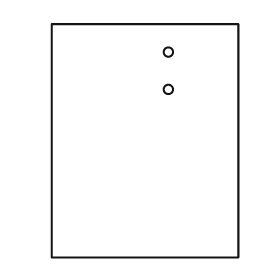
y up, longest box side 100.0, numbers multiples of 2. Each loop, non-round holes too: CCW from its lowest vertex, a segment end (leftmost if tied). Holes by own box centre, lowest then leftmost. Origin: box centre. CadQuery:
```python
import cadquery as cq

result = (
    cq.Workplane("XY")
    .moveTo(-40.0, -50.0)
    .lineTo(40.0, -50.0)
    .lineTo(40.0, 50.0)
    .lineTo(-40.0, 50.0)
    .close()
    .moveTo(10.0, 22.0)
    .circle(2.0)
    .moveTo(10.0, 38.0)
    .circle(2.0)
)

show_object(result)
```